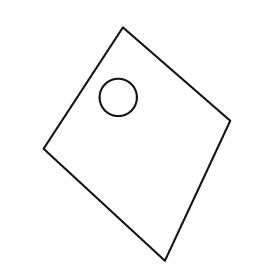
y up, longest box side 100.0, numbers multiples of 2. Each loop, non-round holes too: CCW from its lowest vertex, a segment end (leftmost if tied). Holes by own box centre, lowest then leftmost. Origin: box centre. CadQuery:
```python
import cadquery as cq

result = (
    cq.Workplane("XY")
    .moveTo(12.0, -50.0)
    .lineTo(40.0, 10.0)
    .lineTo(-6.0, 50.0)
    .lineTo(-40.0, -2.0)
    .close()
    .moveTo(-8.0, 20.0)
    .circle(8.0)
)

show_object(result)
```